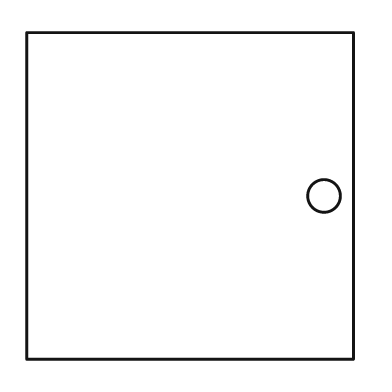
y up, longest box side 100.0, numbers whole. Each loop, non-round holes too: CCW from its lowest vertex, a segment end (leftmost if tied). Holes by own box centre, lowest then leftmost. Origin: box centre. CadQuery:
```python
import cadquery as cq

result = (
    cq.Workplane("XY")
    .moveTo(-50.0, -50.0)
    .lineTo(50.0, -50.0)
    .lineTo(50.0, 50.0)
    .lineTo(-50.0, 50.0)
    .close()
    .moveTo(41.0, 0.0)
    .circle(5.0)
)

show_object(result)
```